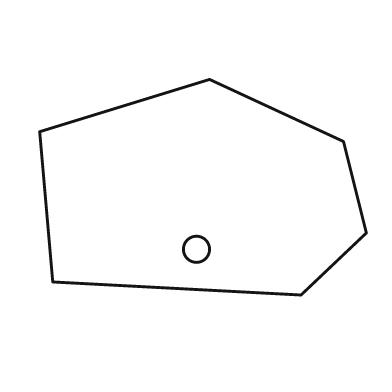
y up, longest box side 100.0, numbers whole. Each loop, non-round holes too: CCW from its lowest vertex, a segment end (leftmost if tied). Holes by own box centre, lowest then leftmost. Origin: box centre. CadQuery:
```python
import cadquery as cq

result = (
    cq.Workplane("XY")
    .moveTo(30.0, -33.0)
    .lineTo(50.0, -14.0)
    .lineTo(43.0, 14.0)
    .lineTo(2.0, 33.0)
    .lineTo(-50.0, 17.0)
    .lineTo(-46.0, -29.0)
    .close()
    .moveTo(-2.0, -19.0)
    .circle(4.0)
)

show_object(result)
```